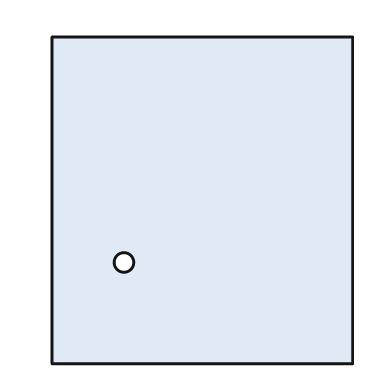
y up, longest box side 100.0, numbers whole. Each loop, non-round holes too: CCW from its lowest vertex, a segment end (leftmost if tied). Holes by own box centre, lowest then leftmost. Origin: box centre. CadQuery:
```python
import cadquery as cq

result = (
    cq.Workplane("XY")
    .moveTo(-46.0, -50.0)
    .lineTo(46.0, -50.0)
    .lineTo(46.0, 50.0)
    .lineTo(-46.0, 50.0)
    .close()
    .moveTo(-24.0, -19.0)
    .circle(3.0)
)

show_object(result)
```